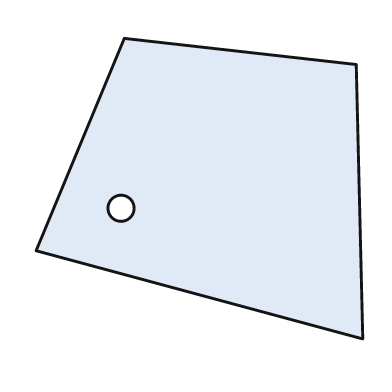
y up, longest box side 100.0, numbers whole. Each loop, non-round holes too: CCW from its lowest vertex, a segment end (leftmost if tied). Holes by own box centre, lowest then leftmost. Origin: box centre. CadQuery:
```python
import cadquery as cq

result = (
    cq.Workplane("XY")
    .moveTo(50.0, -46.0)
    .lineTo(48.0, 38.0)
    .lineTo(-23.0, 46.0)
    .lineTo(-50.0, -19.0)
    .close()
    .moveTo(-24.0, -6.0)
    .circle(4.0)
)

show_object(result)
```